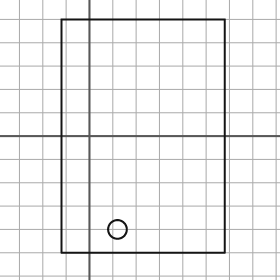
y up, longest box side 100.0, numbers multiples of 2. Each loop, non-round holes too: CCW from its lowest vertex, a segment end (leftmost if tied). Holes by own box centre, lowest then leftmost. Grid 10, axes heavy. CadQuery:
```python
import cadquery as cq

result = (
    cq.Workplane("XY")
    .moveTo(-12.0, -50.0)
    .lineTo(58.0, -50.0)
    .lineTo(58.0, 50.0)
    .lineTo(-12.0, 50.0)
    .close()
    .moveTo(12.0, -40.0)
    .circle(4.0)
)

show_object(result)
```